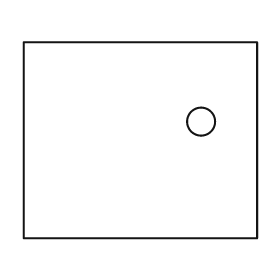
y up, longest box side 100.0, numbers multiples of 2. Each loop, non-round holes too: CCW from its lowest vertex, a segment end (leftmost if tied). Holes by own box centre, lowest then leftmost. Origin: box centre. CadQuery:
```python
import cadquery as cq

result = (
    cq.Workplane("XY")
    .moveTo(-50.0, -42.0)
    .lineTo(50.0, -42.0)
    .lineTo(50.0, 42.0)
    .lineTo(-50.0, 42.0)
    .close()
    .moveTo(26.0, 8.0)
    .circle(6.0)
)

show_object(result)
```